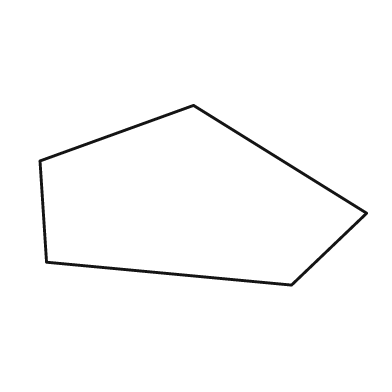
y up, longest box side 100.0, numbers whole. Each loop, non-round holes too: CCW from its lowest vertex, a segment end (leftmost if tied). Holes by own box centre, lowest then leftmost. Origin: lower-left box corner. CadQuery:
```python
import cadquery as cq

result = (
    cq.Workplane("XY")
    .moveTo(77.0, 0.0)
    .lineTo(100.0, 22.0)
    .lineTo(47.0, 55.0)
    .lineTo(0.0, 38.0)
    .lineTo(2.0, 7.0)
    .close()
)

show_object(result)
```